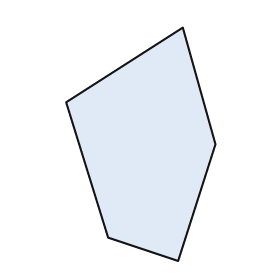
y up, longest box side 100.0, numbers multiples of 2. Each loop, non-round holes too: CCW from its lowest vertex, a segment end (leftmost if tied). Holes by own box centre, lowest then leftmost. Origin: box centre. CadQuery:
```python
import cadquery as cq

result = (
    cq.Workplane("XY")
    .moveTo(16.0, -50.0)
    .lineTo(32.0, 0.0)
    .lineTo(18.0, 50.0)
    .lineTo(-32.0, 18.0)
    .lineTo(-14.0, -40.0)
    .close()
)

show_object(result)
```